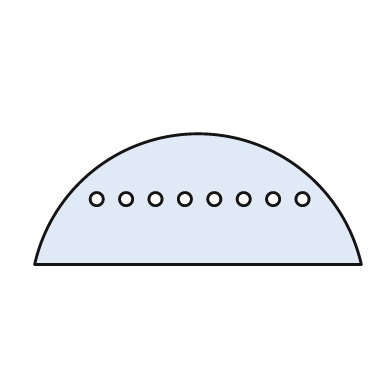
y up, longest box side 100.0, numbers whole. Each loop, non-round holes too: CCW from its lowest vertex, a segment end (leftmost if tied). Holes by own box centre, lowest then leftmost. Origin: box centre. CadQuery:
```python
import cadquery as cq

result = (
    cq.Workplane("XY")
    .moveTo(-50.0, -20.0)
    .lineTo(50.0, -20.0)
    .threePointArc((0.0, 20.0), (-50.0, -20.0))
    .close()
    .moveTo(-31.0, 0.0)
    .circle(2.0)
    .moveTo(-22.0, 0.0)
    .circle(2.0)
    .moveTo(-13.0, 0.0)
    .circle(2.0)
    .moveTo(-4.0, 0.0)
    .circle(2.0)
    .moveTo(5.0, 0.0)
    .circle(2.0)
    .moveTo(14.0, 0.0)
    .circle(2.0)
    .moveTo(23.0, 0.0)
    .circle(2.0)
    .moveTo(32.0, 0.0)
    .circle(2.0)
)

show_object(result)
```